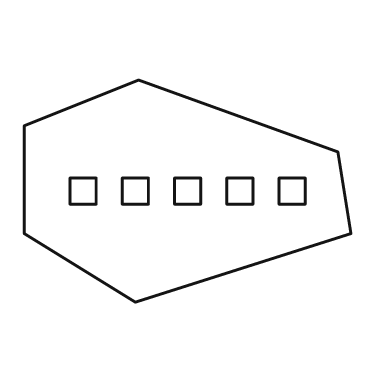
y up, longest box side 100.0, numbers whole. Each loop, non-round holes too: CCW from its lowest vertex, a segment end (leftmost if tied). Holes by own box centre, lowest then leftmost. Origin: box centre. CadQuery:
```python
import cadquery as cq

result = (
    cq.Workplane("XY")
    .moveTo(-16.0, -34.0)
    .lineTo(50.0, -13.0)
    .lineTo(46.0, 12.0)
    .lineTo(-15.0, 34.0)
    .lineTo(-50.0, 20.0)
    .lineTo(-50.0, -13.0)
    .close()
    .moveTo(-36.0, -4.0)
    .lineTo(-28.0, -4.0)
    .lineTo(-28.0, 4.0)
    .lineTo(-36.0, 4.0)
    .close()
    .moveTo(-20.0, -4.0)
    .lineTo(-12.0, -4.0)
    .lineTo(-12.0, 4.0)
    .lineTo(-20.0, 4.0)
    .close()
    .moveTo(-4.0, -4.0)
    .lineTo(4.0, -4.0)
    .lineTo(4.0, 4.0)
    .lineTo(-4.0, 4.0)
    .close()
    .moveTo(12.0, -4.0)
    .lineTo(20.0, -4.0)
    .lineTo(20.0, 4.0)
    .lineTo(12.0, 4.0)
    .close()
    .moveTo(28.0, -4.0)
    .lineTo(36.0, -4.0)
    .lineTo(36.0, 4.0)
    .lineTo(28.0, 4.0)
    .close()
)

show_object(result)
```